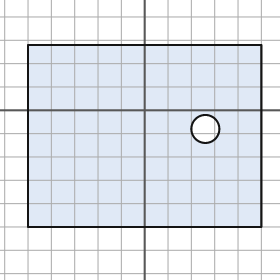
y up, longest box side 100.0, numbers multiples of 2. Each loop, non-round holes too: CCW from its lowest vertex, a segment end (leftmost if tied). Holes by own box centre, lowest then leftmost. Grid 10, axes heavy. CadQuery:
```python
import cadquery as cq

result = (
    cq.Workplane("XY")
    .moveTo(-50.0, -50.0)
    .lineTo(50.0, -50.0)
    .lineTo(50.0, 28.0)
    .lineTo(-50.0, 28.0)
    .close()
    .moveTo(26.0, -8.0)
    .circle(6.0)
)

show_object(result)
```